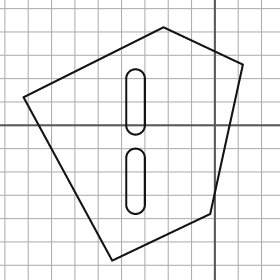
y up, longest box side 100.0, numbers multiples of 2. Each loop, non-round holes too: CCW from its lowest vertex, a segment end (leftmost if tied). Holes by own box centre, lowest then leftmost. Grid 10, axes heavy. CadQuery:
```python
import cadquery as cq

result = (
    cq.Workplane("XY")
    .moveTo(-44.0, -58.0)
    .lineTo(-2.0, -38.0)
    .lineTo(12.0, 26.0)
    .lineTo(-22.0, 42.0)
    .lineTo(-82.0, 12.0)
    .close()
    .moveTo(-38.0, -34.0)
    .threePointArc((-34.0, -38.0), (-30.0, -34.0))
    .lineTo(-30.0, -14.0)
    .threePointArc((-34.0, -10.0), (-38.0, -14.0))
    .close()
    .moveTo(-38.0, 0.0)
    .threePointArc((-34.0, -4.0), (-30.0, 0.0))
    .lineTo(-30.0, 20.0)
    .threePointArc((-34.0, 24.0), (-38.0, 20.0))
    .close()
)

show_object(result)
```